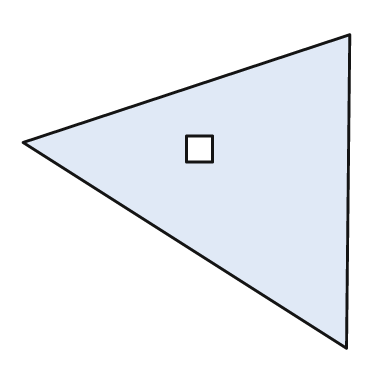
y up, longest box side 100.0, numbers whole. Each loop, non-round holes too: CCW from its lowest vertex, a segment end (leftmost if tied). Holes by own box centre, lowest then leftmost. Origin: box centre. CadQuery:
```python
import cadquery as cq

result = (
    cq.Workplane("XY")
    .moveTo(49.0, -48.0)
    .lineTo(50.0, 48.0)
    .lineTo(-50.0, 15.0)
    .close()
    .moveTo(0.0, 9.0)
    .lineTo(8.0, 9.0)
    .lineTo(8.0, 17.0)
    .lineTo(0.0, 17.0)
    .close()
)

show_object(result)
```